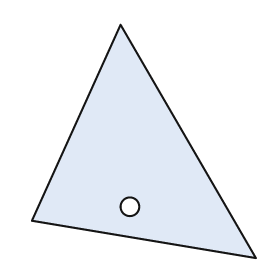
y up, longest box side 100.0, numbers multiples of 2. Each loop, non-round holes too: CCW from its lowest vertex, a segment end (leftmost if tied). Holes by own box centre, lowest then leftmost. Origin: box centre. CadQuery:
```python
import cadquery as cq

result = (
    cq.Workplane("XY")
    .moveTo(48.0, -50.0)
    .lineTo(-10.0, 50.0)
    .lineTo(-48.0, -34.0)
    .close()
    .moveTo(-6.0, -28.0)
    .circle(4.0)
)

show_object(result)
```